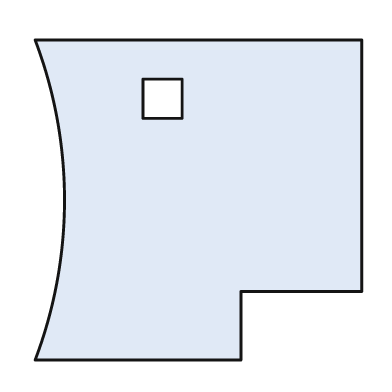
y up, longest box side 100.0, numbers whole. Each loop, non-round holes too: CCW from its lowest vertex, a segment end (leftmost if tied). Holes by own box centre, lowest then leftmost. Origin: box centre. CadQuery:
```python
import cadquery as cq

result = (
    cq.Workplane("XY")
    .moveTo(-50.0, -49.0)
    .lineTo(13.0, -49.0)
    .lineTo(13.0, -28.0)
    .lineTo(50.0, -28.0)
    .lineTo(50.0, 49.0)
    .lineTo(-50.0, 49.0)
    .threePointArc((-41.0, 0.0), (-50.0, -49.0))
    .close()
    .moveTo(-17.0, 25.0)
    .lineTo(-5.0, 25.0)
    .lineTo(-5.0, 37.0)
    .lineTo(-17.0, 37.0)
    .close()
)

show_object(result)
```